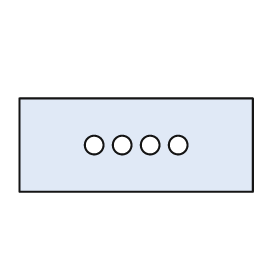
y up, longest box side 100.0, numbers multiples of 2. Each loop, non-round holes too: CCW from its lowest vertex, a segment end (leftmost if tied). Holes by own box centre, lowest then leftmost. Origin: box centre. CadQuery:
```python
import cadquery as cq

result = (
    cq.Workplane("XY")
    .moveTo(-50.0, -20.0)
    .lineTo(50.0, -20.0)
    .lineTo(50.0, 20.0)
    .lineTo(-50.0, 20.0)
    .close()
    .moveTo(-18.0, 0.0)
    .circle(4.0)
    .moveTo(-6.0, 0.0)
    .circle(4.0)
    .moveTo(6.0, 0.0)
    .circle(4.0)
    .moveTo(18.0, 0.0)
    .circle(4.0)
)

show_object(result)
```